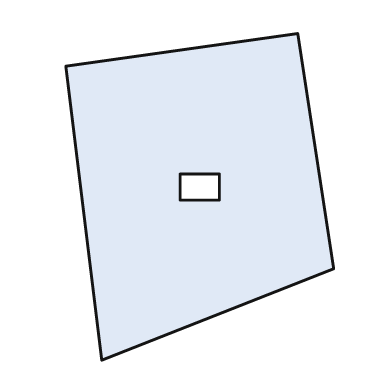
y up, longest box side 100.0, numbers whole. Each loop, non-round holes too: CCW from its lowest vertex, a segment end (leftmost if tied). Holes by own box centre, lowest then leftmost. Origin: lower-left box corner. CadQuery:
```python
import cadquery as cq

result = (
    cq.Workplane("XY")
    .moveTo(11.0, 0.0)
    .lineTo(82.0, 28.0)
    .lineTo(71.0, 100.0)
    .lineTo(0.0, 90.0)
    .close()
    .moveTo(35.0, 49.0)
    .lineTo(47.0, 49.0)
    .lineTo(47.0, 57.0)
    .lineTo(35.0, 57.0)
    .close()
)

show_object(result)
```